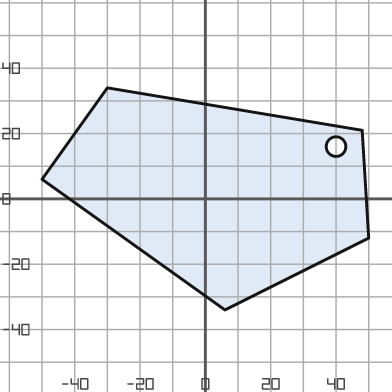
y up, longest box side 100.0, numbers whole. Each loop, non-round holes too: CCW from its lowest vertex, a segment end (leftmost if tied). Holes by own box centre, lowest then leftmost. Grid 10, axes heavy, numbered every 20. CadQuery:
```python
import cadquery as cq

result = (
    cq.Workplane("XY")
    .moveTo(6.0, -34.0)
    .lineTo(50.0, -12.0)
    .lineTo(48.0, 21.0)
    .lineTo(-30.0, 34.0)
    .lineTo(-50.0, 6.0)
    .close()
    .moveTo(40.0, 16.0)
    .circle(3.0)
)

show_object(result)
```